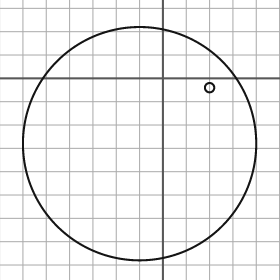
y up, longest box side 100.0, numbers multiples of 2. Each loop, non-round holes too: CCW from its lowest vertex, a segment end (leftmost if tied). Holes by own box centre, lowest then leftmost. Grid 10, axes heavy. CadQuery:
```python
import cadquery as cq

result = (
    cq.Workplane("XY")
    .moveTo(-10.0, -28.0)
    .circle(50.0)
    .moveTo(20.0, -4.0)
    .circle(2.0)
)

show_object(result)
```